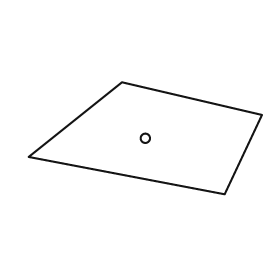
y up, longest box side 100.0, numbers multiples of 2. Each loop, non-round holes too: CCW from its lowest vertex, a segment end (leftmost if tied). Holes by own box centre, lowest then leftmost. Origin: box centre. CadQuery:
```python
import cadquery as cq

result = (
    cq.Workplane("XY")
    .moveTo(34.0, -24.0)
    .lineTo(50.0, 10.0)
    .lineTo(-10.0, 24.0)
    .lineTo(-50.0, -8.0)
    .close()
    .moveTo(0.0, 0.0)
    .circle(2.0)
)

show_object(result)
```